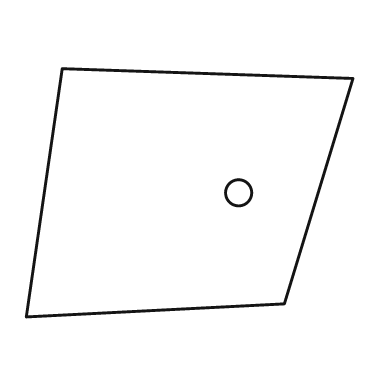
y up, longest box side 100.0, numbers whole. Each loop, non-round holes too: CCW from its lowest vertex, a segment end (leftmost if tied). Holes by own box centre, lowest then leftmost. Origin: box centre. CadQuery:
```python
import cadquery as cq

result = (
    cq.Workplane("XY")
    .moveTo(-50.0, -38.0)
    .lineTo(29.0, -34.0)
    .lineTo(50.0, 35.0)
    .lineTo(-39.0, 38.0)
    .close()
    .moveTo(15.0, 0.0)
    .circle(4.0)
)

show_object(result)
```